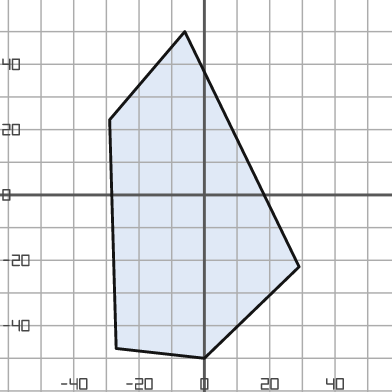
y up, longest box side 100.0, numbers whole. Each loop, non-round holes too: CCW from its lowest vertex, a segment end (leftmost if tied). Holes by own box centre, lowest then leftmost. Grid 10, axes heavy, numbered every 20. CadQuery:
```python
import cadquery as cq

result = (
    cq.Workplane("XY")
    .moveTo(0.0, -50.0)
    .lineTo(29.0, -22.0)
    .lineTo(-6.0, 50.0)
    .lineTo(-29.0, 23.0)
    .lineTo(-27.0, -47.0)
    .close()
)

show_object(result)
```